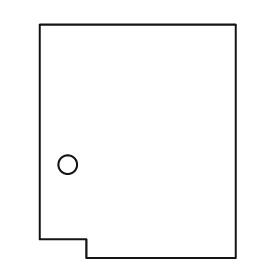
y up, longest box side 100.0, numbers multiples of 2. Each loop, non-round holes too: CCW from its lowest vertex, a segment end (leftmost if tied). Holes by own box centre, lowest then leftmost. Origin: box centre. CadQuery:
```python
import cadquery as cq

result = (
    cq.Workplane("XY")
    .moveTo(-22.0, -50.0)
    .lineTo(42.0, -50.0)
    .lineTo(42.0, 50.0)
    .lineTo(-42.0, 50.0)
    .lineTo(-42.0, -42.0)
    .lineTo(-22.0, -42.0)
    .close()
    .moveTo(-30.0, -10.0)
    .circle(4.0)
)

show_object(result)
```